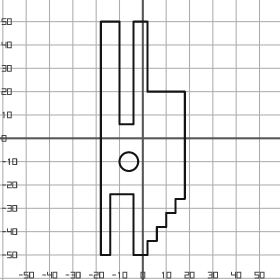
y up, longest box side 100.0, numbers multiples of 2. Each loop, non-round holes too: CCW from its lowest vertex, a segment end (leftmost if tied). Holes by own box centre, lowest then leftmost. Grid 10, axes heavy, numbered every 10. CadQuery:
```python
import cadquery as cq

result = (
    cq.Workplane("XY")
    .moveTo(-18.0, -50.0)
    .lineTo(-14.0, -50.0)
    .lineTo(-14.0, -24.0)
    .lineTo(-4.0, -24.0)
    .lineTo(-4.0, -50.0)
    .lineTo(2.0, -50.0)
    .lineTo(2.0, -44.0)
    .lineTo(6.0, -44.0)
    .lineTo(6.0, -38.0)
    .lineTo(10.0, -38.0)
    .lineTo(10.0, -32.0)
    .lineTo(14.0, -32.0)
    .lineTo(14.0, -26.0)
    .lineTo(18.0, -26.0)
    .lineTo(18.0, 20.0)
    .lineTo(2.0, 20.0)
    .lineTo(2.0, 50.0)
    .lineTo(-4.0, 50.0)
    .lineTo(-4.0, 6.0)
    .lineTo(-10.0, 6.0)
    .lineTo(-10.0, 50.0)
    .lineTo(-18.0, 50.0)
    .close()
    .moveTo(-6.0, -10.0)
    .circle(4.0)
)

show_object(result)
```